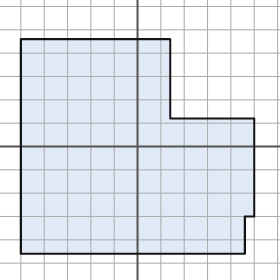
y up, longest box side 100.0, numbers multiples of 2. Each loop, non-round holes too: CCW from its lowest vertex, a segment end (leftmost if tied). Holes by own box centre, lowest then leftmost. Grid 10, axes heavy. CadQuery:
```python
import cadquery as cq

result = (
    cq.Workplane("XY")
    .moveTo(-50.0, -46.0)
    .lineTo(46.0, -46.0)
    .lineTo(46.0, -30.0)
    .lineTo(50.0, -30.0)
    .lineTo(50.0, 12.0)
    .lineTo(14.0, 12.0)
    .lineTo(14.0, 46.0)
    .lineTo(-50.0, 46.0)
    .close()
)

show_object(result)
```